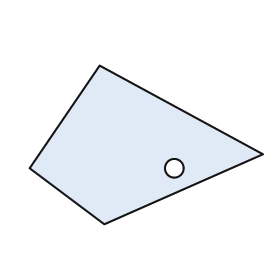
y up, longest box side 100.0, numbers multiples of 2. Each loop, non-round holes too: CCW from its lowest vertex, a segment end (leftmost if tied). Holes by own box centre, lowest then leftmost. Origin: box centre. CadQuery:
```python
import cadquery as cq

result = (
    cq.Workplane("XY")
    .moveTo(-18.0, -34.0)
    .lineTo(50.0, -4.0)
    .lineTo(-20.0, 34.0)
    .lineTo(-50.0, -10.0)
    .close()
    .moveTo(12.0, -10.0)
    .circle(4.0)
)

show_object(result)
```